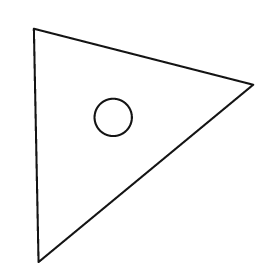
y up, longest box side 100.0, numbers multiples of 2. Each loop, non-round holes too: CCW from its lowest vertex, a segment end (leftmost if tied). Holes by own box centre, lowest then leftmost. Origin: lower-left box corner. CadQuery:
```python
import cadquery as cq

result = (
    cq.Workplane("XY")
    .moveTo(2.0, 0.0)
    .lineTo(94.0, 76.0)
    .lineTo(0.0, 100.0)
    .close()
    .moveTo(34.0, 62.0)
    .circle(8.0)
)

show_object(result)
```